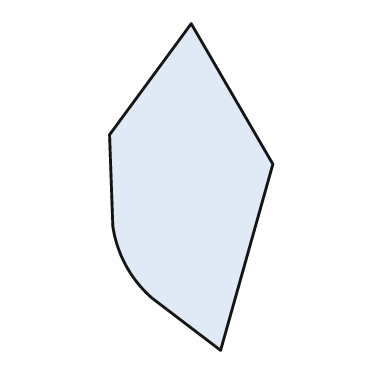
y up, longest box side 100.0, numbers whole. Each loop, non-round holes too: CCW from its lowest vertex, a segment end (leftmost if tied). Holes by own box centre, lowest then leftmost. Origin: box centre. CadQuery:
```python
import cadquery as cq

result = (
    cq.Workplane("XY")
    .moveTo(9.0, -50.0)
    .lineTo(25.0, 7.0)
    .lineTo(0.0, 50.0)
    .lineTo(-25.0, 16.0)
    .lineTo(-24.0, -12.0)
    .threePointArc((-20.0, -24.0), (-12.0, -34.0))
    .close()
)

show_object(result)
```